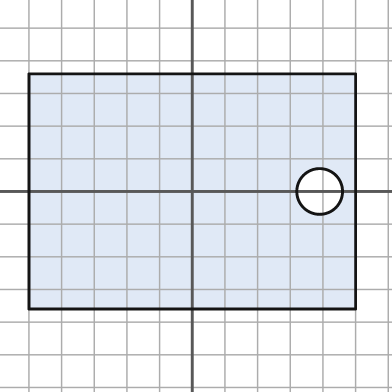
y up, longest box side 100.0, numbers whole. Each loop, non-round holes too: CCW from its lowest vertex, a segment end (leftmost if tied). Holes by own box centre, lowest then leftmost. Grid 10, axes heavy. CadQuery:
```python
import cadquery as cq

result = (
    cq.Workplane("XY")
    .moveTo(-50.0, -36.0)
    .lineTo(50.0, -36.0)
    .lineTo(50.0, 36.0)
    .lineTo(-50.0, 36.0)
    .close()
    .moveTo(39.0, 0.0)
    .circle(7.0)
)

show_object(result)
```